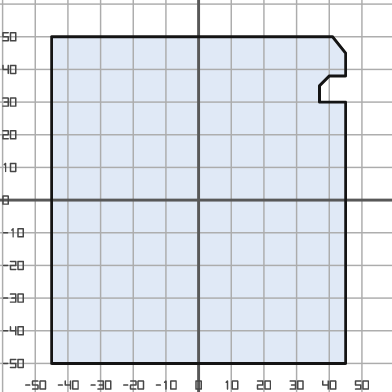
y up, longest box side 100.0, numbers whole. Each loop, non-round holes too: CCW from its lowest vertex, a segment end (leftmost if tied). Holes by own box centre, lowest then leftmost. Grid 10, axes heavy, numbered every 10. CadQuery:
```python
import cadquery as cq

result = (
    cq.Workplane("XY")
    .moveTo(-45.0, -50.0)
    .lineTo(45.0, -50.0)
    .lineTo(45.0, 30.0)
    .lineTo(37.0, 30.0)
    .lineTo(37.0, 35.0)
    .lineTo(40.0, 38.0)
    .lineTo(45.0, 38.0)
    .lineTo(45.0, 45.0)
    .lineTo(41.0, 50.0)
    .lineTo(-45.0, 50.0)
    .close()
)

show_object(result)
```